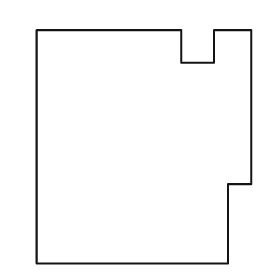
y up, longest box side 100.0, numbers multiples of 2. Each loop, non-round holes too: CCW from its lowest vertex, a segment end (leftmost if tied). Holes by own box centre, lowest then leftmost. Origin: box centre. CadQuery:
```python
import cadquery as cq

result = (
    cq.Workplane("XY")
    .moveTo(-46.0, -50.0)
    .lineTo(36.0, -50.0)
    .lineTo(36.0, -16.0)
    .lineTo(46.0, -16.0)
    .lineTo(46.0, 50.0)
    .lineTo(30.0, 50.0)
    .lineTo(30.0, 36.0)
    .lineTo(16.0, 36.0)
    .lineTo(16.0, 50.0)
    .lineTo(-46.0, 50.0)
    .close()
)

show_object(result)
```